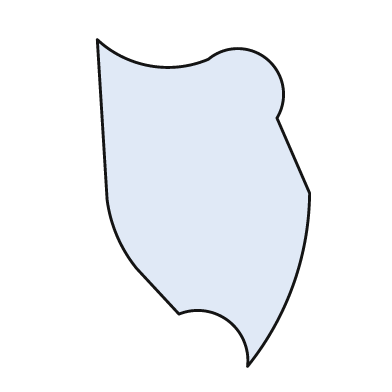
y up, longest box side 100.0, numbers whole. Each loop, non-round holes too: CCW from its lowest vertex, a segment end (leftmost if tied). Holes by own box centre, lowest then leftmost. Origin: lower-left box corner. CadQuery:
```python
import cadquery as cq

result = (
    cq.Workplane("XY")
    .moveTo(46.0, 0.0)
    .threePointArc((60.0, 25.0), (65.0, 53.0))
    .lineTo(55.0, 76.0)
    .threePointArc((52.0, 94.0), (34.0, 94.0))
    .threePointArc((16.0, 92.0), (0.0, 100.0))
    .lineTo(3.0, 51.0)
    .threePointArc((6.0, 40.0), (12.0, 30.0))
    .lineTo(25.0, 16.0)
    .threePointArc((40.0, 14.0), (46.0, 0.0))
    .close()
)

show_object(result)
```